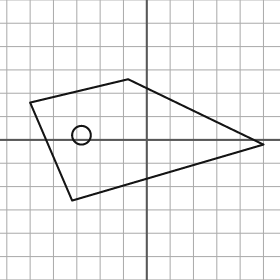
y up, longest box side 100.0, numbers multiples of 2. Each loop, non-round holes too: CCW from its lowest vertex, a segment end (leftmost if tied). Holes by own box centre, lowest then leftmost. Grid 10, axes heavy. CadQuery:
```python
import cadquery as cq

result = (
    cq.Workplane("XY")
    .moveTo(-32.0, -26.0)
    .lineTo(50.0, -2.0)
    .lineTo(-8.0, 26.0)
    .lineTo(-50.0, 16.0)
    .close()
    .moveTo(-28.0, 2.0)
    .circle(4.0)
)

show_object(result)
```